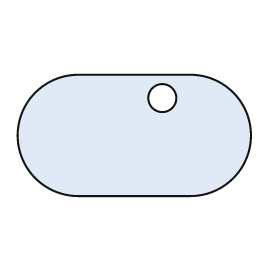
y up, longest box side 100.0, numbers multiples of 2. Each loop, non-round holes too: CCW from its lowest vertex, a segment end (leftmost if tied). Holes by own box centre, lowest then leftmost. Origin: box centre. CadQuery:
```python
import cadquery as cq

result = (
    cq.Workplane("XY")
    .moveTo(-24.0, -26.0)
    .lineTo(24.0, -26.0)
    .threePointArc((50.0, 0.0), (24.0, 26.0))
    .lineTo(-24.0, 26.0)
    .threePointArc((-50.0, 0.0), (-24.0, -26.0))
    .close()
    .moveTo(12.0, 16.0)
    .circle(6.0)
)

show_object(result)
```